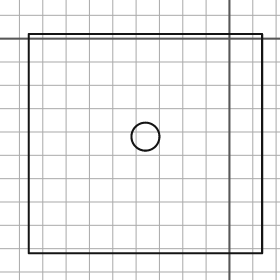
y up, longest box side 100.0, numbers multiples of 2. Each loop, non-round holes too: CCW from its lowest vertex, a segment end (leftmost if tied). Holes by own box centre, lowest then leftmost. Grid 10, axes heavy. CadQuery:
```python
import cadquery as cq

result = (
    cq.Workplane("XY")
    .moveTo(-86.0, -92.0)
    .lineTo(14.0, -92.0)
    .lineTo(14.0, 2.0)
    .lineTo(-86.0, 2.0)
    .close()
    .moveTo(-36.0, -42.0)
    .circle(6.0)
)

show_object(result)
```